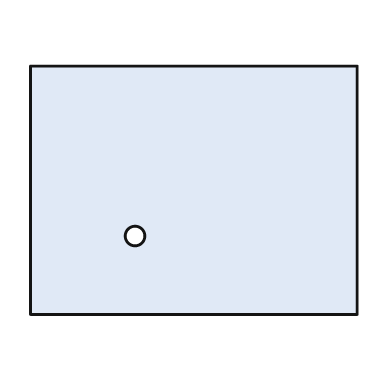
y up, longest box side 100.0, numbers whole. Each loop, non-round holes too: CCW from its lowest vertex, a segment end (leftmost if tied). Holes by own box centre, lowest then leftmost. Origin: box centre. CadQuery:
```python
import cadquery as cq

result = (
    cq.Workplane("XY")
    .moveTo(-50.0, -38.0)
    .lineTo(50.0, -38.0)
    .lineTo(50.0, 38.0)
    .lineTo(-50.0, 38.0)
    .close()
    .moveTo(-18.0, -14.0)
    .circle(3.0)
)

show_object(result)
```